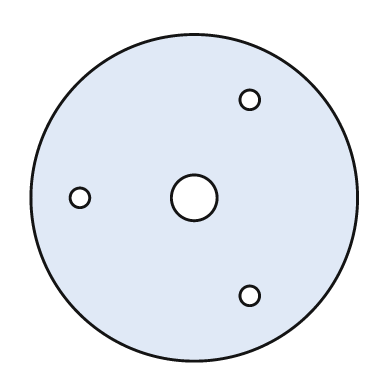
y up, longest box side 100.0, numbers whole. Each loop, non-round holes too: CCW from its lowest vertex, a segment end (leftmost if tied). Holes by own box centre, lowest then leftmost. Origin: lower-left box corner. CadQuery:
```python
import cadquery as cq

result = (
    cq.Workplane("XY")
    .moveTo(50.0, 50.0)
    .circle(50.0)
    .moveTo(67.0, 20.0)
    .circle(3.0)
    .moveTo(15.0, 50.0)
    .circle(3.0)
    .moveTo(50.0, 50.0)
    .circle(7.0)
    .moveTo(67.0, 80.0)
    .circle(3.0)
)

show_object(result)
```